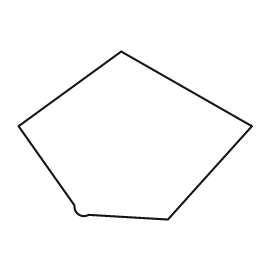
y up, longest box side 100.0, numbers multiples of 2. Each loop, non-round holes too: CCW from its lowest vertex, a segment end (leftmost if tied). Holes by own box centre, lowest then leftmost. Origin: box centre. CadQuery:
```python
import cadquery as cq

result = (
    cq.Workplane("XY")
    .moveTo(14.0, -36.0)
    .lineTo(50.0, 4.0)
    .lineTo(-6.0, 36.0)
    .lineTo(-50.0, 4.0)
    .lineTo(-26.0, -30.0)
    .threePointArc((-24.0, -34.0), (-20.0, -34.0))
    .close()
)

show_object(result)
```